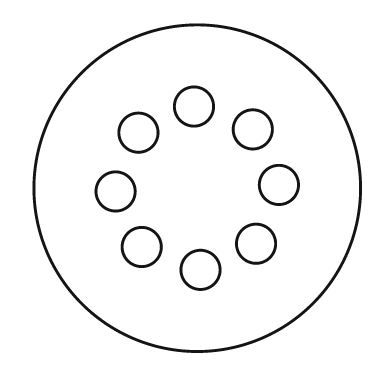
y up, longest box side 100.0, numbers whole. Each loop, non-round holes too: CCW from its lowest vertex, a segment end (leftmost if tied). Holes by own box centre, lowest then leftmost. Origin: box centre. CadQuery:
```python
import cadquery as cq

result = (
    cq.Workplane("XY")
    .moveTo(0.0, 0.0)
    .circle(50.0)
    .moveTo(1.0, -25.0)
    .circle(6.0)
    .moveTo(-17.0, -18.0)
    .circle(6.0)
    .moveTo(18.0, -17.0)
    .circle(6.0)
    .moveTo(-25.0, -1.0)
    .circle(6.0)
    .moveTo(25.0, 1.0)
    .circle(6.0)
    .moveTo(-18.0, 17.0)
    .circle(6.0)
    .moveTo(17.0, 18.0)
    .circle(6.0)
    .moveTo(-1.0, 25.0)
    .circle(6.0)
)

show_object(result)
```